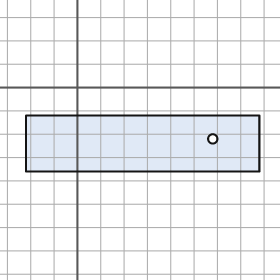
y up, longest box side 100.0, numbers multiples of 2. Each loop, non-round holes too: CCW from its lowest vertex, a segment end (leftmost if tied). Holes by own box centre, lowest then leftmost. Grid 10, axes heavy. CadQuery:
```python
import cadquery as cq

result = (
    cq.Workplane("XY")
    .moveTo(-22.0, -36.0)
    .lineTo(78.0, -36.0)
    .lineTo(78.0, -12.0)
    .lineTo(-22.0, -12.0)
    .close()
    .moveTo(58.0, -22.0)
    .circle(2.0)
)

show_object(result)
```